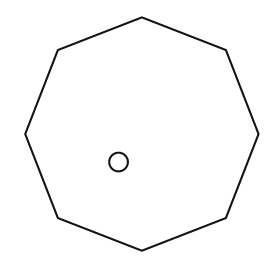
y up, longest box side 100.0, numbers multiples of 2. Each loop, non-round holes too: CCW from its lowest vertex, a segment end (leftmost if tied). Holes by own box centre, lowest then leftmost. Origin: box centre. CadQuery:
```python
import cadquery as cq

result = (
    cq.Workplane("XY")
    .moveTo(0.0, -50.0)
    .lineTo(36.0, -36.0)
    .lineTo(50.0, 0.0)
    .lineTo(36.0, 36.0)
    .lineTo(0.0, 50.0)
    .lineTo(-36.0, 36.0)
    .lineTo(-50.0, 0.0)
    .lineTo(-36.0, -36.0)
    .close()
    .moveTo(-10.0, -12.0)
    .circle(4.0)
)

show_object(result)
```